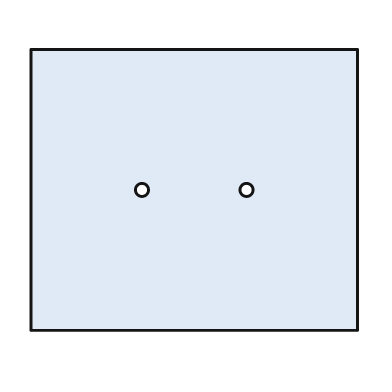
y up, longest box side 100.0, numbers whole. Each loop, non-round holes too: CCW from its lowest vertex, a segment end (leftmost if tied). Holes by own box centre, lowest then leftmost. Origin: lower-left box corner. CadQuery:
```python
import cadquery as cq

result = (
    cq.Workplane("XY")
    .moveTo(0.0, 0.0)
    .lineTo(100.0, 0.0)
    .lineTo(100.0, 86.0)
    .lineTo(0.0, 86.0)
    .close()
    .moveTo(34.0, 43.0)
    .circle(2.0)
    .moveTo(66.0, 43.0)
    .circle(2.0)
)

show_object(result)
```